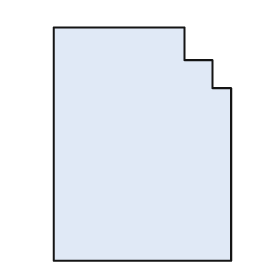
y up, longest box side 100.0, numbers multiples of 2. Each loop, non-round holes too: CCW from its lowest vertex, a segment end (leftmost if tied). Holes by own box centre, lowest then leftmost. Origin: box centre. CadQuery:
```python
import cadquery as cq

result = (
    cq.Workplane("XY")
    .moveTo(-38.0, -50.0)
    .lineTo(38.0, -50.0)
    .lineTo(38.0, 24.0)
    .lineTo(30.0, 24.0)
    .lineTo(30.0, 36.0)
    .lineTo(18.0, 36.0)
    .lineTo(18.0, 50.0)
    .lineTo(-38.0, 50.0)
    .close()
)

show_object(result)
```